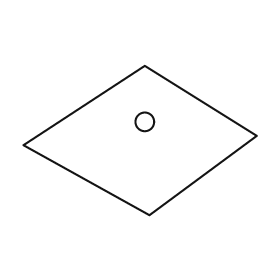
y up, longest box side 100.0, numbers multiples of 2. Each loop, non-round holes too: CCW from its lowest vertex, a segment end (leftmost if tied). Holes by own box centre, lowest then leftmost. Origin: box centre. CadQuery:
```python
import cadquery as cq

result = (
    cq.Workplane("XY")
    .moveTo(4.0, -32.0)
    .lineTo(50.0, 2.0)
    .lineTo(2.0, 32.0)
    .lineTo(-50.0, -2.0)
    .close()
    .moveTo(2.0, 8.0)
    .circle(4.0)
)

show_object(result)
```